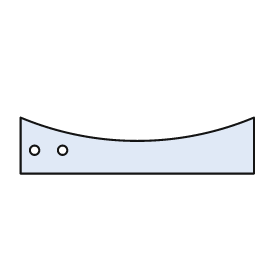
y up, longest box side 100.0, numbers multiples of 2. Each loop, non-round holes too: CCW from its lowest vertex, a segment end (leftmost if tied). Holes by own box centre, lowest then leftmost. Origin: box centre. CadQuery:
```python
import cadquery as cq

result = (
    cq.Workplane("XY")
    .moveTo(-50.0, -12.0)
    .lineTo(50.0, -12.0)
    .lineTo(50.0, 12.0)
    .threePointArc((0.0, 2.0), (-50.0, 12.0))
    .close()
    .moveTo(-44.0, -2.0)
    .circle(2.0)
    .moveTo(-32.0, -2.0)
    .circle(2.0)
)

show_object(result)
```